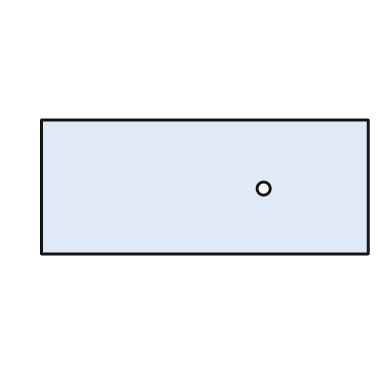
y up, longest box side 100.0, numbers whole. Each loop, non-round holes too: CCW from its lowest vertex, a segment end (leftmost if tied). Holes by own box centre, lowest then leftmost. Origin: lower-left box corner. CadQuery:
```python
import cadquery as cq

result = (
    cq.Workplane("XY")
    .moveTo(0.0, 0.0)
    .lineTo(100.0, 0.0)
    .lineTo(100.0, 41.0)
    .lineTo(0.0, 41.0)
    .close()
    .moveTo(68.0, 20.0)
    .circle(2.0)
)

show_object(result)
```